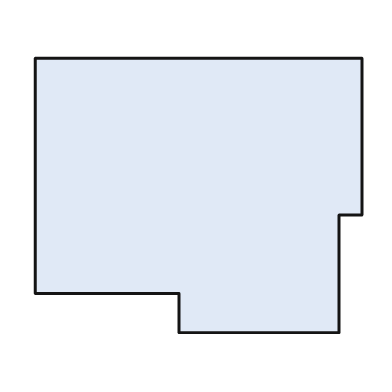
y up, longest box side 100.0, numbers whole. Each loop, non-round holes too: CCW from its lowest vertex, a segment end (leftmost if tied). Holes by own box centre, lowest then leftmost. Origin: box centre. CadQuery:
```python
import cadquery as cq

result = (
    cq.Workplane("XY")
    .moveTo(-6.0, -42.0)
    .lineTo(43.0, -42.0)
    .lineTo(43.0, -6.0)
    .lineTo(50.0, -6.0)
    .lineTo(50.0, 42.0)
    .lineTo(-50.0, 42.0)
    .lineTo(-50.0, -30.0)
    .lineTo(-6.0, -30.0)
    .close()
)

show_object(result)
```